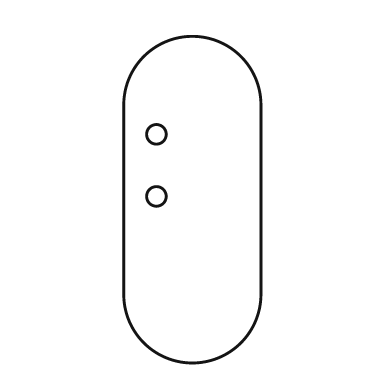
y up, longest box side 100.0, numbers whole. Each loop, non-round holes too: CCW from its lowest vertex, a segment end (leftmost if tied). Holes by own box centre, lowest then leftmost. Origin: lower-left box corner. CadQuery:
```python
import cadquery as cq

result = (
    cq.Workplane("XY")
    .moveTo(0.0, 21.0)
    .threePointArc((21.0, 0.0), (42.0, 21.0))
    .lineTo(42.0, 79.0)
    .threePointArc((21.0, 100.0), (0.0, 79.0))
    .close()
    .moveTo(10.0, 51.0)
    .circle(3.0)
    .moveTo(10.0, 70.0)
    .circle(3.0)
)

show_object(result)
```